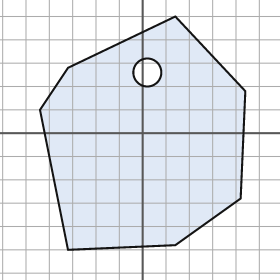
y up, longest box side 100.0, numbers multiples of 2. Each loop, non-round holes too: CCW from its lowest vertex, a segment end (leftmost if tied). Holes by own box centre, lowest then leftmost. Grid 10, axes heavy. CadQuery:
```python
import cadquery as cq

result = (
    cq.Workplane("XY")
    .moveTo(-32.0, -50.0)
    .lineTo(14.0, -48.0)
    .lineTo(42.0, -28.0)
    .lineTo(44.0, 18.0)
    .lineTo(14.0, 50.0)
    .lineTo(-32.0, 28.0)
    .lineTo(-44.0, 10.0)
    .close()
    .moveTo(2.0, 26.0)
    .circle(6.0)
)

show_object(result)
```